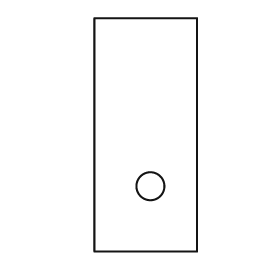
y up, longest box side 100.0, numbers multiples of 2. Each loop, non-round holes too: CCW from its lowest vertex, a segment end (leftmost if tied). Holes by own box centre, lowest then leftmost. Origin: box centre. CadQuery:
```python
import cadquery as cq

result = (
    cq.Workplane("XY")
    .moveTo(-22.0, -50.0)
    .lineTo(22.0, -50.0)
    .lineTo(22.0, 50.0)
    .lineTo(-22.0, 50.0)
    .close()
    .moveTo(2.0, -22.0)
    .circle(6.0)
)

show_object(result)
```